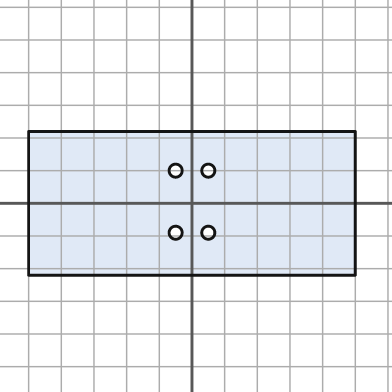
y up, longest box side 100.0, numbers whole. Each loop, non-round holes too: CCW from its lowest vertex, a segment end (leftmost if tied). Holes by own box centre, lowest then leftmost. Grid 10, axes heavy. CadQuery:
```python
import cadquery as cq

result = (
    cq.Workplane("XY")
    .moveTo(-50.0, -22.0)
    .lineTo(50.0, -22.0)
    .lineTo(50.0, 22.0)
    .lineTo(-50.0, 22.0)
    .close()
    .moveTo(-5.0, -9.0)
    .circle(2.0)
    .moveTo(5.0, -9.0)
    .circle(2.0)
    .moveTo(-5.0, 10.0)
    .circle(2.0)
    .moveTo(5.0, 10.0)
    .circle(2.0)
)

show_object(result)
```